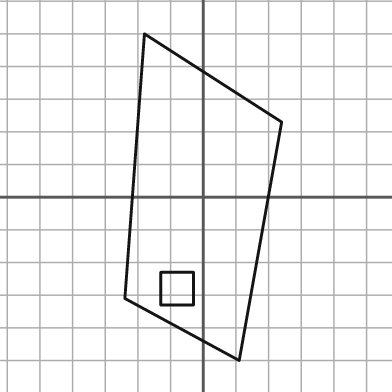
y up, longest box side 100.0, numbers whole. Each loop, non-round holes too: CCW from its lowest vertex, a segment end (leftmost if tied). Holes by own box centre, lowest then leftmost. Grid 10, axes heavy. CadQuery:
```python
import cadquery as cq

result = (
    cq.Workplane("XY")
    .moveTo(11.0, -50.0)
    .lineTo(24.0, 23.0)
    .lineTo(-18.0, 50.0)
    .lineTo(-24.0, -31.0)
    .close()
    .moveTo(-13.0, -33.0)
    .lineTo(-3.0, -33.0)
    .lineTo(-3.0, -23.0)
    .lineTo(-13.0, -23.0)
    .close()
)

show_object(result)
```